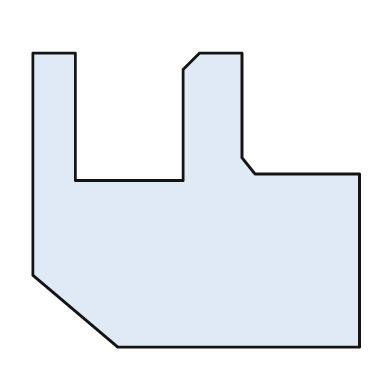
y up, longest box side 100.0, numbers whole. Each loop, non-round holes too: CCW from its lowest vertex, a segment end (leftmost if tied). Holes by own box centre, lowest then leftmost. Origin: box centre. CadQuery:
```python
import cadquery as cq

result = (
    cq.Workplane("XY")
    .moveTo(-24.0, -45.0)
    .lineTo(50.0, -45.0)
    .lineTo(50.0, 8.0)
    .lineTo(18.0, 8.0)
    .lineTo(14.0, 13.0)
    .lineTo(14.0, 45.0)
    .lineTo(1.0, 45.0)
    .lineTo(-4.0, 40.0)
    .lineTo(-4.0, 6.0)
    .lineTo(-37.0, 6.0)
    .lineTo(-37.0, 45.0)
    .lineTo(-50.0, 45.0)
    .lineTo(-50.0, -23.0)
    .close()
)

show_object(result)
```